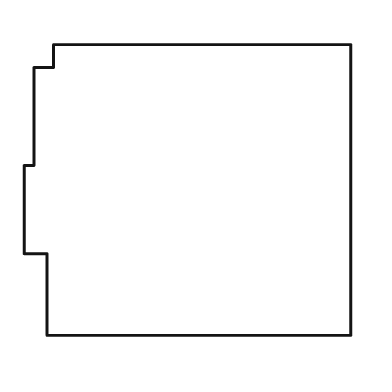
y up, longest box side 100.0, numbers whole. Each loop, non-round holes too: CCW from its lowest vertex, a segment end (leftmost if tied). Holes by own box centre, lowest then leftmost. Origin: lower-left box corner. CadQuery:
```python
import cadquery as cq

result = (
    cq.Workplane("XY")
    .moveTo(7.0, 0.0)
    .lineTo(100.0, 0.0)
    .lineTo(100.0, 89.0)
    .lineTo(9.0, 89.0)
    .lineTo(9.0, 82.0)
    .lineTo(3.0, 82.0)
    .lineTo(3.0, 52.0)
    .lineTo(0.0, 52.0)
    .lineTo(0.0, 25.0)
    .lineTo(7.0, 25.0)
    .close()
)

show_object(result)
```